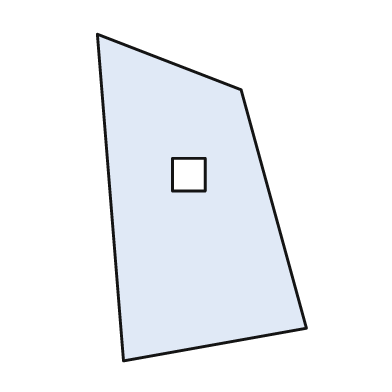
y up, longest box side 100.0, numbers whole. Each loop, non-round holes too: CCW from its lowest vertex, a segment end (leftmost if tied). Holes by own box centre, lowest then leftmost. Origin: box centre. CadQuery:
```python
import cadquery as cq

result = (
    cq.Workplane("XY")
    .moveTo(-24.0, -50.0)
    .lineTo(32.0, -40.0)
    .lineTo(12.0, 33.0)
    .lineTo(-32.0, 50.0)
    .close()
    .moveTo(-9.0, 2.0)
    .lineTo(1.0, 2.0)
    .lineTo(1.0, 12.0)
    .lineTo(-9.0, 12.0)
    .close()
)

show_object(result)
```